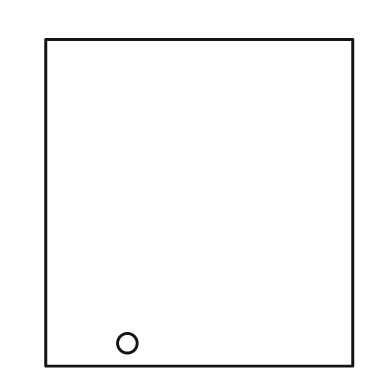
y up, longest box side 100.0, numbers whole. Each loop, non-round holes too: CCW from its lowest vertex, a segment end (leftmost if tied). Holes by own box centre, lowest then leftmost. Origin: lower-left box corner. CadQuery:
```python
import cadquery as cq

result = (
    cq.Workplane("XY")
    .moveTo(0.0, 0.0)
    .lineTo(94.0, 0.0)
    .lineTo(94.0, 100.0)
    .lineTo(0.0, 100.0)
    .close()
    .moveTo(25.0, 7.0)
    .circle(3.0)
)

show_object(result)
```